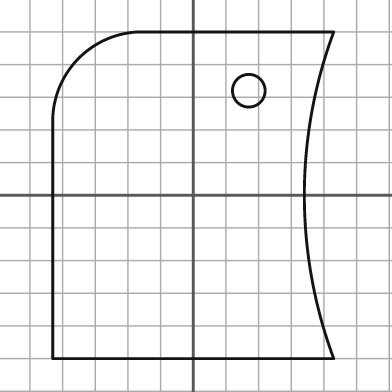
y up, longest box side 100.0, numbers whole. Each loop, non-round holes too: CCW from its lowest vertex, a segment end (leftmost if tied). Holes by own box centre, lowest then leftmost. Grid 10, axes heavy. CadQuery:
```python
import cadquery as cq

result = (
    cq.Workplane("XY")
    .moveTo(-43.0, -50.0)
    .lineTo(43.0, -50.0)
    .threePointArc((34.0, 0.0), (43.0, 50.0))
    .lineTo(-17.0, 50.0)
    .threePointArc((-35.0, 42.0), (-43.0, 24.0))
    .close()
    .moveTo(17.0, 32.0)
    .circle(5.0)
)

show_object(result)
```